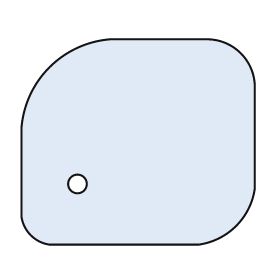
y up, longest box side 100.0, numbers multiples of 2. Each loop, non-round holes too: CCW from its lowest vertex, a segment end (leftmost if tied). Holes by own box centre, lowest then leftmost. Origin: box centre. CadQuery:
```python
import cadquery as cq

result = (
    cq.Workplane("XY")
    .moveTo(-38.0, -44.0)
    .lineTo(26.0, -44.0)
    .threePointArc((42.0, -36.0), (50.0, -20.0))
    .lineTo(50.0, 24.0)
    .threePointArc((44.0, 38.0), (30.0, 44.0))
    .lineTo(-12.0, 44.0)
    .threePointArc((-38.0, 32.0), (-50.0, 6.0))
    .lineTo(-50.0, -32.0)
    .threePointArc((-46.0, -40.0), (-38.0, -44.0))
    .close()
    .moveTo(-26.0, -18.0)
    .circle(4.0)
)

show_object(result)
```